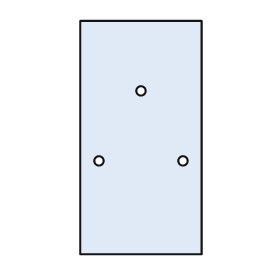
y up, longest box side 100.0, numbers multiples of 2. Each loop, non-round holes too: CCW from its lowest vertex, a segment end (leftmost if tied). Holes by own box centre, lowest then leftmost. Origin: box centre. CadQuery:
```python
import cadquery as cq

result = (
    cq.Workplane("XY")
    .moveTo(-26.0, -50.0)
    .lineTo(26.0, -50.0)
    .lineTo(26.0, 50.0)
    .lineTo(-26.0, 50.0)
    .close()
    .moveTo(-18.0, -10.0)
    .circle(2.0)
    .moveTo(18.0, -10.0)
    .circle(2.0)
    .moveTo(0.0, 20.0)
    .circle(2.0)
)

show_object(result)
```